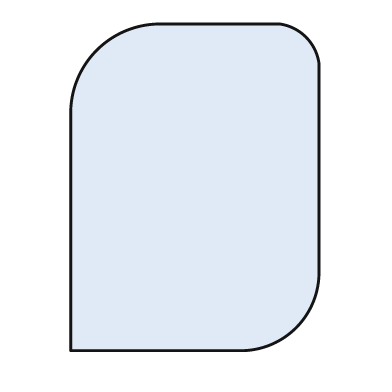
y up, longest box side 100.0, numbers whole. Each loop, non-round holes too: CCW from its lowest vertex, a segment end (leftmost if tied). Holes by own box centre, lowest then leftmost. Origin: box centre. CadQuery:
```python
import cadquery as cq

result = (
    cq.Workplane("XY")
    .moveTo(-38.0, -50.0)
    .lineTo(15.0, -50.0)
    .threePointArc((31.0, -43.0), (38.0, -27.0))
    .lineTo(38.0, 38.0)
    .threePointArc((34.0, 46.0), (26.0, 50.0))
    .lineTo(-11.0, 50.0)
    .threePointArc((-30.0, 42.0), (-38.0, 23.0))
    .close()
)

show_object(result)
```